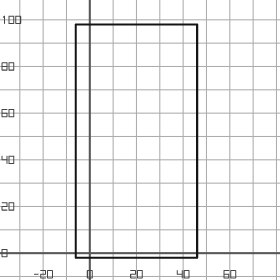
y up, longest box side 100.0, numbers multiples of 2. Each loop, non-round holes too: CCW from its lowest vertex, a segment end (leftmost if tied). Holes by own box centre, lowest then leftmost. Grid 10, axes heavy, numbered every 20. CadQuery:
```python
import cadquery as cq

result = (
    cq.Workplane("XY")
    .moveTo(-6.0, -2.0)
    .lineTo(46.0, -2.0)
    .lineTo(46.0, 98.0)
    .lineTo(-6.0, 98.0)
    .close()
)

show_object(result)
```